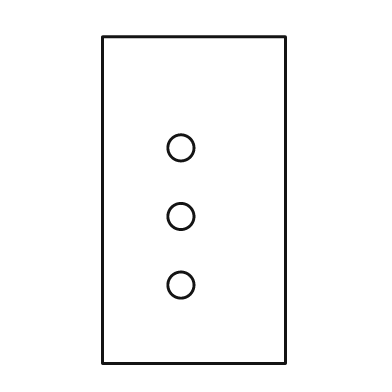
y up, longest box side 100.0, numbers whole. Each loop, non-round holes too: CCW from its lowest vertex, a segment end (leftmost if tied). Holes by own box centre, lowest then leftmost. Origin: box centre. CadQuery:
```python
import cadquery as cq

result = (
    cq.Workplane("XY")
    .moveTo(-28.0, -50.0)
    .lineTo(28.0, -50.0)
    .lineTo(28.0, 50.0)
    .lineTo(-28.0, 50.0)
    .close()
    .moveTo(-4.0, -26.0)
    .circle(4.0)
    .moveTo(-4.0, -5.0)
    .circle(4.0)
    .moveTo(-4.0, 16.0)
    .circle(4.0)
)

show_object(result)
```